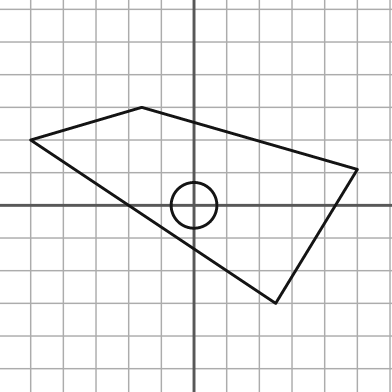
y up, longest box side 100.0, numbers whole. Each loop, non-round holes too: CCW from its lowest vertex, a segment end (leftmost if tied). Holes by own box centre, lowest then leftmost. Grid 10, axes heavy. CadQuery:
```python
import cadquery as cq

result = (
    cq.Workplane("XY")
    .moveTo(25.0, -30.0)
    .lineTo(50.0, 11.0)
    .lineTo(-16.0, 30.0)
    .lineTo(-50.0, 20.0)
    .close()
    .moveTo(0.0, 0.0)
    .circle(7.0)
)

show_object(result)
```